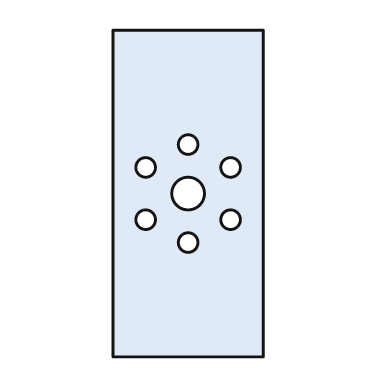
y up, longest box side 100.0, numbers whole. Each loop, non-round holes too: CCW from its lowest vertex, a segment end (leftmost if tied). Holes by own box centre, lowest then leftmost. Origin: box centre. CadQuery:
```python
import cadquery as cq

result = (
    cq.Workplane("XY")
    .moveTo(-23.0, -50.0)
    .lineTo(23.0, -50.0)
    .lineTo(23.0, 50.0)
    .lineTo(-23.0, 50.0)
    .close()
    .moveTo(0.0, -15.0)
    .circle(3.0)
    .moveTo(-13.0, -8.0)
    .circle(3.0)
    .moveTo(13.0, -8.0)
    .circle(3.0)
    .moveTo(0.0, 0.0)
    .circle(5.0)
    .moveTo(-13.0, 8.0)
    .circle(3.0)
    .moveTo(13.0, 8.0)
    .circle(3.0)
    .moveTo(0.0, 15.0)
    .circle(3.0)
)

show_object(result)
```